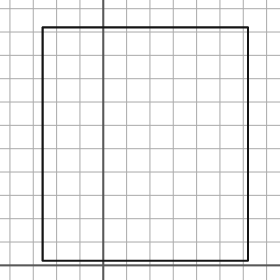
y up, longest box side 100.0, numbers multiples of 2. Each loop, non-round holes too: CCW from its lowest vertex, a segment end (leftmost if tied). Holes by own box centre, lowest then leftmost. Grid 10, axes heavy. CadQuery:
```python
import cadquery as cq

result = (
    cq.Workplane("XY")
    .moveTo(-26.0, 2.0)
    .lineTo(62.0, 2.0)
    .lineTo(62.0, 102.0)
    .lineTo(-26.0, 102.0)
    .close()
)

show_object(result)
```